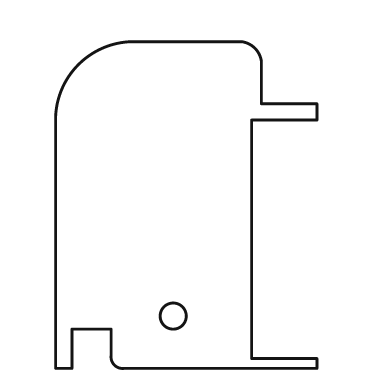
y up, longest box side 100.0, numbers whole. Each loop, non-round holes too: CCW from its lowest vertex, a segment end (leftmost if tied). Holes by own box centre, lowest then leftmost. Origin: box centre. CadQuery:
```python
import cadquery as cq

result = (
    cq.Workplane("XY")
    .moveTo(-40.0, -50.0)
    .lineTo(-35.0, -50.0)
    .lineTo(-35.0, -38.0)
    .lineTo(-23.0, -38.0)
    .lineTo(-23.0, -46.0)
    .threePointArc((-22.0, -49.0), (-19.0, -50.0))
    .lineTo(40.0, -50.0)
    .lineTo(40.0, -47.0)
    .lineTo(20.0, -47.0)
    .lineTo(20.0, 26.0)
    .lineTo(40.0, 26.0)
    .lineTo(40.0, 31.0)
    .lineTo(23.0, 31.0)
    .lineTo(23.0, 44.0)
    .threePointArc((21.0, 48.0), (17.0, 50.0))
    .lineTo(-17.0, 50.0)
    .threePointArc((-33.0, 43.0), (-40.0, 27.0))
    .close()
    .moveTo(-4.0, -34.0)
    .circle(4.0)
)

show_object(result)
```